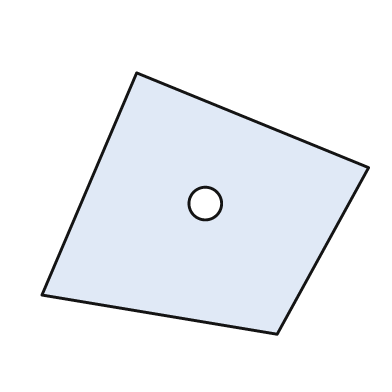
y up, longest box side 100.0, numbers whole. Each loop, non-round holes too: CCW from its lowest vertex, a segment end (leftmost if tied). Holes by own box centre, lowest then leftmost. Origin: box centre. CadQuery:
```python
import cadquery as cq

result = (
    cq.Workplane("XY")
    .moveTo(22.0, -40.0)
    .lineTo(50.0, 11.0)
    .lineTo(-21.0, 40.0)
    .lineTo(-50.0, -28.0)
    .close()
    .moveTo(0.0, 0.0)
    .circle(5.0)
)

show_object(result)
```